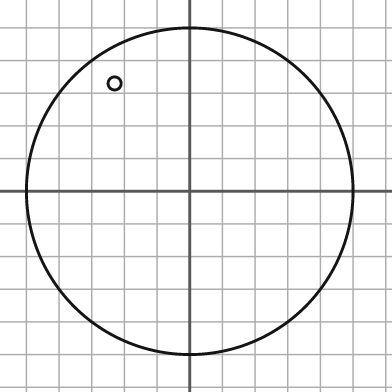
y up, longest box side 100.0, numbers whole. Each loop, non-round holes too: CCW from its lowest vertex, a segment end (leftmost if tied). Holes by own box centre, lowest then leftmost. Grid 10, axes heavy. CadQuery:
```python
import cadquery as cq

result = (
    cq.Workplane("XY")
    .moveTo(0.0, 0.0)
    .circle(50.0)
    .moveTo(-23.0, 33.0)
    .circle(2.0)
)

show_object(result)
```